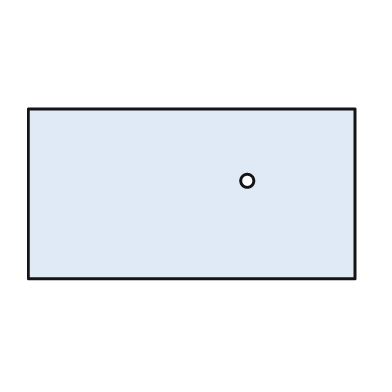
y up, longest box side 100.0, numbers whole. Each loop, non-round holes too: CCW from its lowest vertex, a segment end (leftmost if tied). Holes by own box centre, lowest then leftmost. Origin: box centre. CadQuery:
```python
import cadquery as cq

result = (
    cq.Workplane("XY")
    .moveTo(-50.0, -26.0)
    .lineTo(50.0, -26.0)
    .lineTo(50.0, 26.0)
    .lineTo(-50.0, 26.0)
    .close()
    .moveTo(17.0, 4.0)
    .circle(2.0)
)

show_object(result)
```